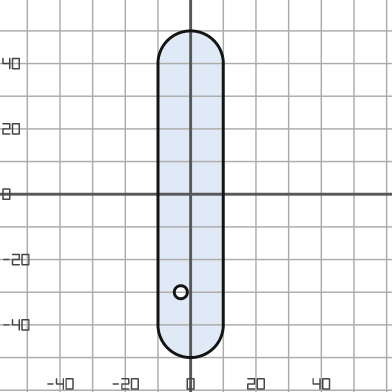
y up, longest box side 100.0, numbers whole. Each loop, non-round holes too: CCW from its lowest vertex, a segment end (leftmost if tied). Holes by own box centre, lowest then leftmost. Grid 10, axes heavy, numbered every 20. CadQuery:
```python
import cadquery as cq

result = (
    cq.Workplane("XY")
    .moveTo(-10.0, -40.0)
    .threePointArc((0.0, -50.0), (10.0, -40.0))
    .lineTo(10.0, 40.0)
    .threePointArc((0.0, 50.0), (-10.0, 40.0))
    .close()
    .moveTo(-3.0, -30.0)
    .circle(2.0)
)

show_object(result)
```